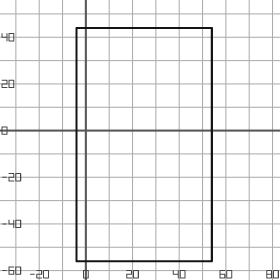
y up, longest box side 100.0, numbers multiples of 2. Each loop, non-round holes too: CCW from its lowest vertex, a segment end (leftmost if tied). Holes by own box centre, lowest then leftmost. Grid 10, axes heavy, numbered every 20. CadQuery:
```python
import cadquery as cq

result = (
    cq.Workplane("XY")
    .moveTo(-4.0, -56.0)
    .lineTo(54.0, -56.0)
    .lineTo(54.0, 44.0)
    .lineTo(-4.0, 44.0)
    .close()
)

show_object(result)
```